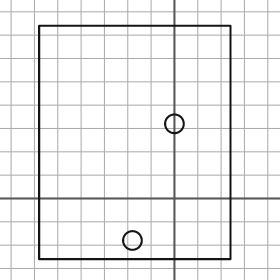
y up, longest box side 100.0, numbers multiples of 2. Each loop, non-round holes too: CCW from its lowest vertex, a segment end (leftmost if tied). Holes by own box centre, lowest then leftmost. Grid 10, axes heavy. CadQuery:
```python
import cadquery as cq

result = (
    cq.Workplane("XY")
    .moveTo(-58.0, -26.0)
    .lineTo(24.0, -26.0)
    .lineTo(24.0, 74.0)
    .lineTo(-58.0, 74.0)
    .close()
    .moveTo(-18.0, -18.0)
    .circle(4.0)
    .moveTo(0.0, 32.0)
    .circle(4.0)
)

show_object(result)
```